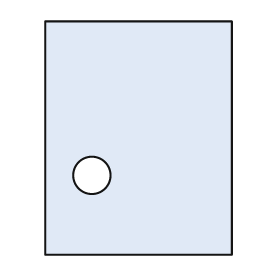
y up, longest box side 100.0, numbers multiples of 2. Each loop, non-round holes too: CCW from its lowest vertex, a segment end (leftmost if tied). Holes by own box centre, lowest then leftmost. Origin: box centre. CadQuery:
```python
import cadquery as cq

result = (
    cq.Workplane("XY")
    .moveTo(-40.0, -50.0)
    .lineTo(40.0, -50.0)
    .lineTo(40.0, 50.0)
    .lineTo(-40.0, 50.0)
    .close()
    .moveTo(-20.0, -16.0)
    .circle(8.0)
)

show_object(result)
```